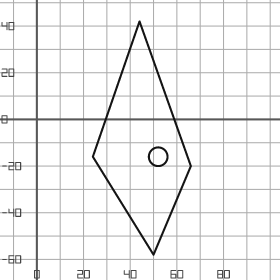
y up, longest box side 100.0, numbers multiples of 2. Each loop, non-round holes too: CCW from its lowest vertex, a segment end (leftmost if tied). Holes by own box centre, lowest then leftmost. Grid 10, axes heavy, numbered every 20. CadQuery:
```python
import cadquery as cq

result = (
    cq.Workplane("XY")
    .moveTo(50.0, -58.0)
    .lineTo(66.0, -20.0)
    .lineTo(44.0, 42.0)
    .lineTo(24.0, -16.0)
    .close()
    .moveTo(52.0, -16.0)
    .circle(4.0)
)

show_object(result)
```